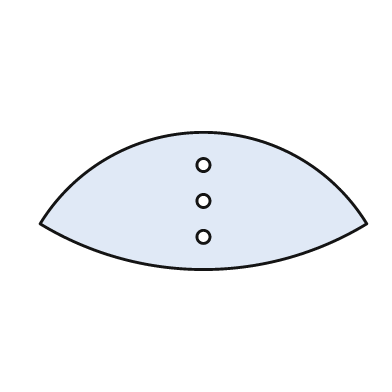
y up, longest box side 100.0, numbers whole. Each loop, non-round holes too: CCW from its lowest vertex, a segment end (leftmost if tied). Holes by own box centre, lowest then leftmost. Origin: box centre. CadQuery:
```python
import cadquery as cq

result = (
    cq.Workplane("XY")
    .moveTo(-50.0, -7.0)
    .threePointArc((0.0, -21.0), (50.0, -7.0))
    .threePointArc((0.0, 21.0), (-50.0, -7.0))
    .close()
    .moveTo(0.0, -11.0)
    .circle(2.0)
    .moveTo(0.0, 0.0)
    .circle(2.0)
    .moveTo(0.0, 11.0)
    .circle(2.0)
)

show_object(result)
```